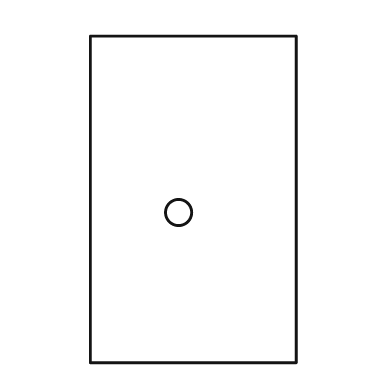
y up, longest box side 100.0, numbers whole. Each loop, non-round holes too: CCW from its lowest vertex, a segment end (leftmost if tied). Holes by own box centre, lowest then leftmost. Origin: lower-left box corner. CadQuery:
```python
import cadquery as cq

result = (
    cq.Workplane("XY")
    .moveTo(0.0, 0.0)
    .lineTo(63.0, 0.0)
    .lineTo(63.0, 100.0)
    .lineTo(0.0, 100.0)
    .close()
    .moveTo(27.0, 46.0)
    .circle(4.0)
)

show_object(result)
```